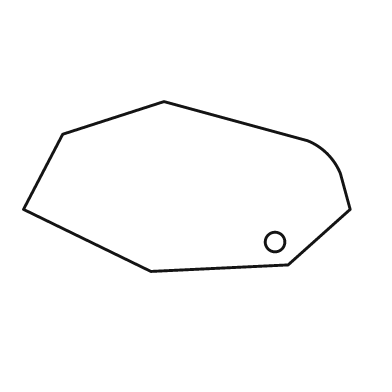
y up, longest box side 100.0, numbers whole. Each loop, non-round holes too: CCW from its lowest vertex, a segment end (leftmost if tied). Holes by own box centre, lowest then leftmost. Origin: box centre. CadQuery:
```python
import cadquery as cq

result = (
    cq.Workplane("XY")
    .moveTo(-11.0, -26.0)
    .lineTo(31.0, -24.0)
    .lineTo(50.0, -7.0)
    .lineTo(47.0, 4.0)
    .threePointArc((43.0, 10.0), (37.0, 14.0))
    .lineTo(-7.0, 26.0)
    .lineTo(-38.0, 16.0)
    .lineTo(-50.0, -7.0)
    .close()
    .moveTo(27.0, -17.0)
    .circle(3.0)
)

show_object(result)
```